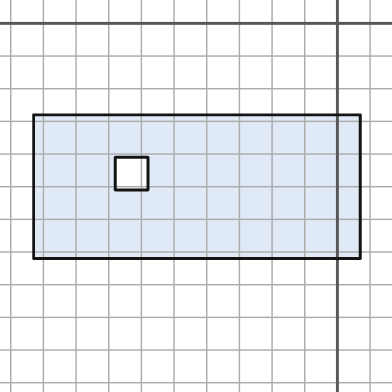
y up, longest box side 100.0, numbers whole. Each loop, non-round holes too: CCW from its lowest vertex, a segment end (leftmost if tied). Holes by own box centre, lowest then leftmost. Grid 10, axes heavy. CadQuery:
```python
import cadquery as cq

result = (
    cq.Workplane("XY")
    .moveTo(-93.0, -72.0)
    .lineTo(7.0, -72.0)
    .lineTo(7.0, -28.0)
    .lineTo(-93.0, -28.0)
    .close()
    .moveTo(-68.0, -51.0)
    .lineTo(-58.0, -51.0)
    .lineTo(-58.0, -41.0)
    .lineTo(-68.0, -41.0)
    .close()
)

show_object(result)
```